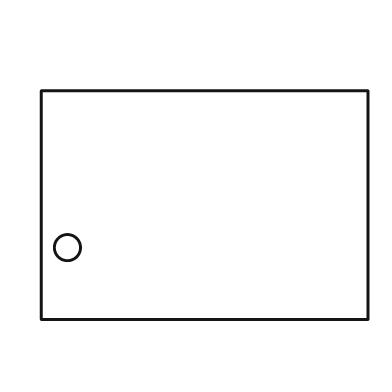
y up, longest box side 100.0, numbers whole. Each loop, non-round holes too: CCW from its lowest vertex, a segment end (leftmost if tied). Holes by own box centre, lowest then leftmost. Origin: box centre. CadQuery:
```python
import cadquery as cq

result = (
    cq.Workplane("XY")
    .moveTo(-50.0, -35.0)
    .lineTo(50.0, -35.0)
    .lineTo(50.0, 35.0)
    .lineTo(-50.0, 35.0)
    .close()
    .moveTo(-42.0, -13.0)
    .circle(4.0)
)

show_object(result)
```